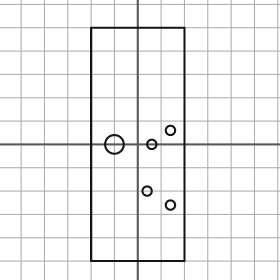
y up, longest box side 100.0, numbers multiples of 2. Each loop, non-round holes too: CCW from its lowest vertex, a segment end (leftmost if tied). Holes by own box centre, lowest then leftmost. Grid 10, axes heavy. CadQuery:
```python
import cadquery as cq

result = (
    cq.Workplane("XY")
    .moveTo(-20.0, -50.0)
    .lineTo(20.0, -50.0)
    .lineTo(20.0, 50.0)
    .lineTo(-20.0, 50.0)
    .close()
    .moveTo(14.0, -26.0)
    .circle(2.0)
    .moveTo(4.0, -20.0)
    .circle(2.0)
    .moveTo(-10.0, 0.0)
    .circle(4.0)
    .moveTo(6.0, 0.0)
    .circle(2.0)
    .moveTo(14.0, 6.0)
    .circle(2.0)
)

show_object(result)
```